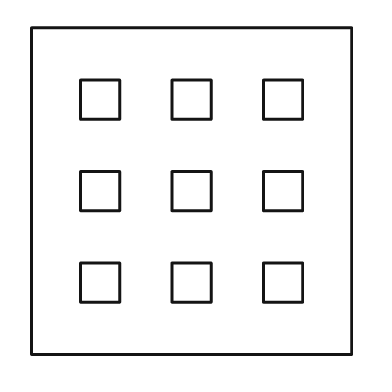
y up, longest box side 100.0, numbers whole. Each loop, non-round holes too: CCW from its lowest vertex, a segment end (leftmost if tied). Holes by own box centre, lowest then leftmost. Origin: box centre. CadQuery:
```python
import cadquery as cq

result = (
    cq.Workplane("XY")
    .moveTo(-49.0, -50.0)
    .lineTo(49.0, -50.0)
    .lineTo(49.0, 50.0)
    .lineTo(-49.0, 50.0)
    .close()
    .moveTo(-34.0, -34.0)
    .lineTo(-22.0, -34.0)
    .lineTo(-22.0, -22.0)
    .lineTo(-34.0, -22.0)
    .close()
    .moveTo(-6.0, -34.0)
    .lineTo(6.0, -34.0)
    .lineTo(6.0, -22.0)
    .lineTo(-6.0, -22.0)
    .close()
    .moveTo(22.0, -34.0)
    .lineTo(34.0, -34.0)
    .lineTo(34.0, -22.0)
    .lineTo(22.0, -22.0)
    .close()
    .moveTo(-34.0, -6.0)
    .lineTo(-22.0, -6.0)
    .lineTo(-22.0, 6.0)
    .lineTo(-34.0, 6.0)
    .close()
    .moveTo(-6.0, -6.0)
    .lineTo(6.0, -6.0)
    .lineTo(6.0, 6.0)
    .lineTo(-6.0, 6.0)
    .close()
    .moveTo(22.0, -6.0)
    .lineTo(34.0, -6.0)
    .lineTo(34.0, 6.0)
    .lineTo(22.0, 6.0)
    .close()
    .moveTo(-34.0, 22.0)
    .lineTo(-22.0, 22.0)
    .lineTo(-22.0, 34.0)
    .lineTo(-34.0, 34.0)
    .close()
    .moveTo(-6.0, 22.0)
    .lineTo(6.0, 22.0)
    .lineTo(6.0, 34.0)
    .lineTo(-6.0, 34.0)
    .close()
    .moveTo(22.0, 22.0)
    .lineTo(34.0, 22.0)
    .lineTo(34.0, 34.0)
    .lineTo(22.0, 34.0)
    .close()
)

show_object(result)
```